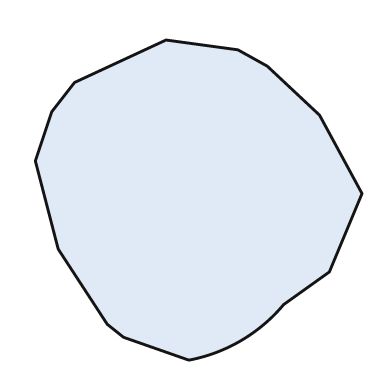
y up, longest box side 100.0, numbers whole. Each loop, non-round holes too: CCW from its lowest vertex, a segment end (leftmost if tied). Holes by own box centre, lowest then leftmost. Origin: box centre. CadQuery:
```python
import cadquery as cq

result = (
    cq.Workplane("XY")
    .moveTo(-3.0, -49.0)
    .threePointArc((13.0, -43.0), (26.0, -32.0))
    .lineTo(40.0, -22.0)
    .lineTo(50.0, 2.0)
    .lineTo(37.0, 26.0)
    .lineTo(21.0, 41.0)
    .lineTo(12.0, 46.0)
    .lineTo(-10.0, 49.0)
    .lineTo(-38.0, 36.0)
    .lineTo(-45.0, 27.0)
    .lineTo(-50.0, 12.0)
    .lineTo(-43.0, -15.0)
    .lineTo(-28.0, -38.0)
    .lineTo(-23.0, -42.0)
    .close()
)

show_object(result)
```